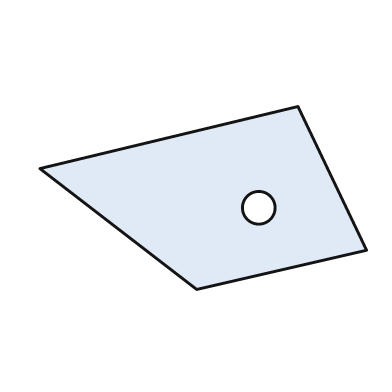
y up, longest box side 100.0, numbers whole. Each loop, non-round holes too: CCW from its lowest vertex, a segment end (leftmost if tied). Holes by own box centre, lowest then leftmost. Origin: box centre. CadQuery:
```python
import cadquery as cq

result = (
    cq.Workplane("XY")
    .moveTo(-2.0, -28.0)
    .lineTo(50.0, -16.0)
    .lineTo(29.0, 28.0)
    .lineTo(-50.0, 9.0)
    .close()
    .moveTo(17.0, -3.0)
    .circle(5.0)
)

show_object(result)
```